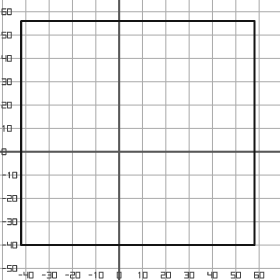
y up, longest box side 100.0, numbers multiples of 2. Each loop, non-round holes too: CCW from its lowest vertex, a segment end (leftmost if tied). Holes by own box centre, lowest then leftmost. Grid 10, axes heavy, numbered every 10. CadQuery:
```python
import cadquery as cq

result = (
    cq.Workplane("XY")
    .moveTo(-42.0, -40.0)
    .lineTo(58.0, -40.0)
    .lineTo(58.0, 56.0)
    .lineTo(-42.0, 56.0)
    .close()
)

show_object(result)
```